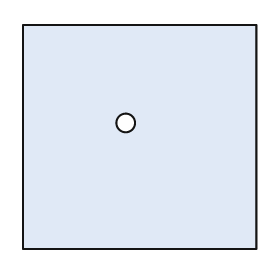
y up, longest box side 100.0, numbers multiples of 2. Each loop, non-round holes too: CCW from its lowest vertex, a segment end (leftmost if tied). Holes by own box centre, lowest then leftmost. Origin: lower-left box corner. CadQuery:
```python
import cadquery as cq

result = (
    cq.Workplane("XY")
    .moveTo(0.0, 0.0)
    .lineTo(100.0, 0.0)
    .lineTo(100.0, 96.0)
    .lineTo(0.0, 96.0)
    .close()
    .moveTo(44.0, 54.0)
    .circle(4.0)
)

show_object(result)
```